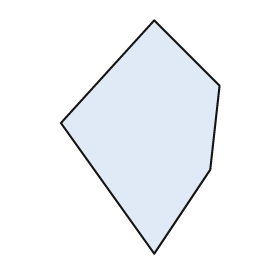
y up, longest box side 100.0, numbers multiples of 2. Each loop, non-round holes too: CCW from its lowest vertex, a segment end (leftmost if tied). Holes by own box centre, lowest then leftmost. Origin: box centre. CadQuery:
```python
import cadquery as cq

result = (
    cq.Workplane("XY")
    .moveTo(6.0, -50.0)
    .lineTo(30.0, -14.0)
    .lineTo(34.0, 22.0)
    .lineTo(6.0, 50.0)
    .lineTo(-34.0, 6.0)
    .close()
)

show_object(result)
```